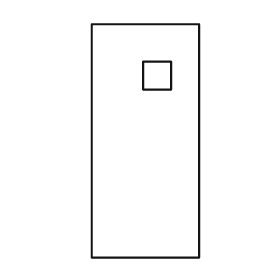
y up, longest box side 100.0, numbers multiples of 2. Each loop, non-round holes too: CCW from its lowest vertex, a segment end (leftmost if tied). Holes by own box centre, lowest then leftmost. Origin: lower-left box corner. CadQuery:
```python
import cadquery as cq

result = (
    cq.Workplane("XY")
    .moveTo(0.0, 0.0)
    .lineTo(46.0, 0.0)
    .lineTo(46.0, 100.0)
    .lineTo(0.0, 100.0)
    .close()
    .moveTo(22.0, 72.0)
    .lineTo(34.0, 72.0)
    .lineTo(34.0, 84.0)
    .lineTo(22.0, 84.0)
    .close()
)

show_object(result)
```